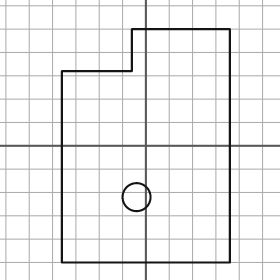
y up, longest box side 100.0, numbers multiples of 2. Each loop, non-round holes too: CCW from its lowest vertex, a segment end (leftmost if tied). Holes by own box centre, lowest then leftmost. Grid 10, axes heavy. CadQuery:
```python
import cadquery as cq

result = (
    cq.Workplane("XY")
    .moveTo(-36.0, -50.0)
    .lineTo(36.0, -50.0)
    .lineTo(36.0, 50.0)
    .lineTo(-6.0, 50.0)
    .lineTo(-6.0, 32.0)
    .lineTo(-36.0, 32.0)
    .close()
    .moveTo(-4.0, -22.0)
    .circle(6.0)
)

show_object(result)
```